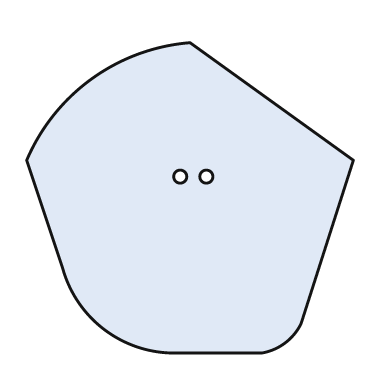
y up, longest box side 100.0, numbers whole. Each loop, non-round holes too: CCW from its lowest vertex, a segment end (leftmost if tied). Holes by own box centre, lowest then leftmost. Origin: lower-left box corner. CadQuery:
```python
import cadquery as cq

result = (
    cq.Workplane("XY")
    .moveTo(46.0, 0.0)
    .lineTo(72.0, 0.0)
    .threePointArc((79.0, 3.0), (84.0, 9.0))
    .lineTo(100.0, 59.0)
    .lineTo(50.0, 95.0)
    .threePointArc((20.0, 84.0), (0.0, 59.0))
    .lineTo(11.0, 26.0)
    .threePointArc((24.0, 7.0), (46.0, 0.0))
    .close()
    .moveTo(47.0, 54.0)
    .circle(2.0)
    .moveTo(55.0, 54.0)
    .circle(2.0)
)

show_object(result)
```